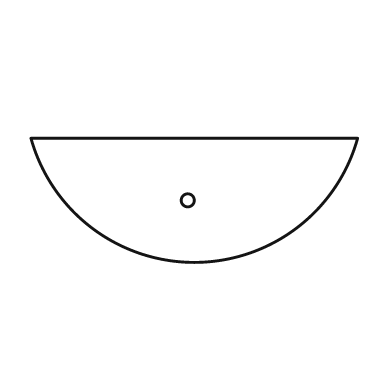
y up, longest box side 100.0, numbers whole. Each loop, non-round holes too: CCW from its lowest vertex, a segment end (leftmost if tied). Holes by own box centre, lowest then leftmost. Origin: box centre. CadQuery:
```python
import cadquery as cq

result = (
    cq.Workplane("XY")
    .moveTo(-50.0, 19.0)
    .threePointArc((0.0, -19.0), (50.0, 19.0))
    .close()
    .moveTo(-2.0, 0.0)
    .circle(2.0)
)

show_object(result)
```